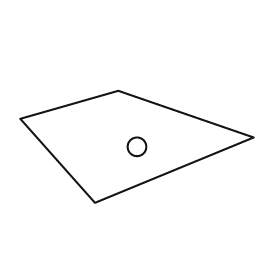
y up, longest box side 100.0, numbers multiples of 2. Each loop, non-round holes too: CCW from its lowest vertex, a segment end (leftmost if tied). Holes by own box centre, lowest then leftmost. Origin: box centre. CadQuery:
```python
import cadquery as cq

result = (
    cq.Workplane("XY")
    .moveTo(-18.0, -24.0)
    .lineTo(50.0, 4.0)
    .lineTo(-8.0, 24.0)
    .lineTo(-50.0, 12.0)
    .close()
    .moveTo(0.0, 0.0)
    .circle(4.0)
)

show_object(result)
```